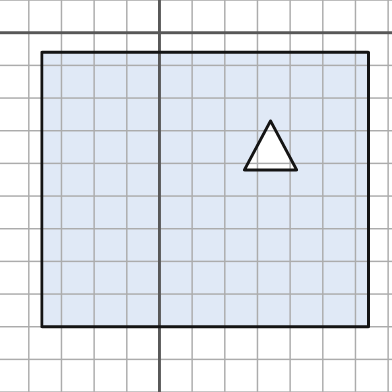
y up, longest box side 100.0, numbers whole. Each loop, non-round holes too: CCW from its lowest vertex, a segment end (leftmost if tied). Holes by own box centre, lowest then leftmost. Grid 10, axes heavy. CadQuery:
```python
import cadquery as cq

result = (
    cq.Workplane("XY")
    .moveTo(-36.0, -90.0)
    .lineTo(64.0, -90.0)
    .lineTo(64.0, -6.0)
    .lineTo(-36.0, -6.0)
    .close()
    .moveTo(26.0, -42.0)
    .lineTo(42.0, -42.0)
    .lineTo(34.0, -27.0)
    .close()
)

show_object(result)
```